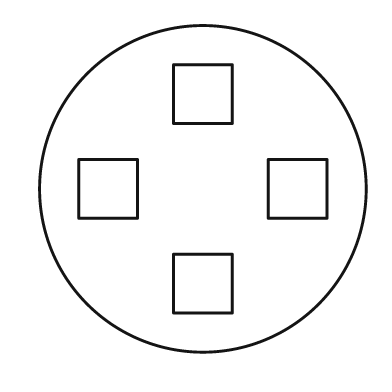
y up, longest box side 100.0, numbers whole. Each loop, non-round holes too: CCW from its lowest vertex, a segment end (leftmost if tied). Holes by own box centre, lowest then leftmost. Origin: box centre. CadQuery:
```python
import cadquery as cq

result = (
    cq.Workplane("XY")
    .moveTo(0.0, 0.0)
    .circle(50.0)
    .moveTo(-9.0, -38.0)
    .lineTo(9.0, -38.0)
    .lineTo(9.0, -20.0)
    .lineTo(-9.0, -20.0)
    .close()
    .moveTo(-38.0, -9.0)
    .lineTo(-20.0, -9.0)
    .lineTo(-20.0, 9.0)
    .lineTo(-38.0, 9.0)
    .close()
    .moveTo(20.0, -9.0)
    .lineTo(38.0, -9.0)
    .lineTo(38.0, 9.0)
    .lineTo(20.0, 9.0)
    .close()
    .moveTo(-9.0, 20.0)
    .lineTo(9.0, 20.0)
    .lineTo(9.0, 38.0)
    .lineTo(-9.0, 38.0)
    .close()
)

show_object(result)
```